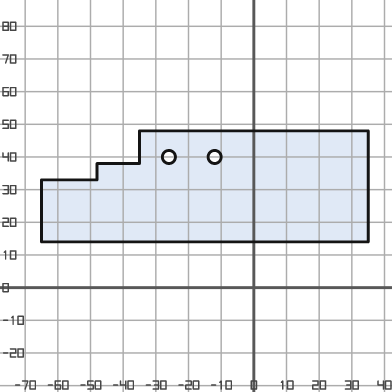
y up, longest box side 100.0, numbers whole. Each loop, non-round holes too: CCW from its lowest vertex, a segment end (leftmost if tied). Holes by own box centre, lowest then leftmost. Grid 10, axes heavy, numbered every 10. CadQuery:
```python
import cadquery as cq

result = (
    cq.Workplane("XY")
    .moveTo(-65.0, 14.0)
    .lineTo(35.0, 14.0)
    .lineTo(35.0, 48.0)
    .lineTo(-35.0, 48.0)
    .lineTo(-35.0, 38.0)
    .lineTo(-48.0, 38.0)
    .lineTo(-48.0, 33.0)
    .lineTo(-65.0, 33.0)
    .close()
    .moveTo(-26.0, 40.0)
    .circle(2.0)
    .moveTo(-12.0, 40.0)
    .circle(2.0)
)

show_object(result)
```